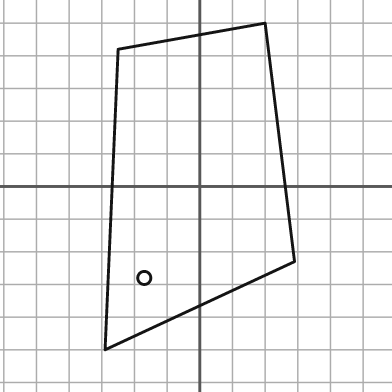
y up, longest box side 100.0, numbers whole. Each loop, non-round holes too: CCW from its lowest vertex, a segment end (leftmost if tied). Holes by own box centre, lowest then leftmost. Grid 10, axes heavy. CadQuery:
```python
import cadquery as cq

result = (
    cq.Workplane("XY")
    .moveTo(-29.0, -50.0)
    .lineTo(29.0, -23.0)
    .lineTo(20.0, 50.0)
    .lineTo(-25.0, 42.0)
    .close()
    .moveTo(-17.0, -28.0)
    .circle(2.0)
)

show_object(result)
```